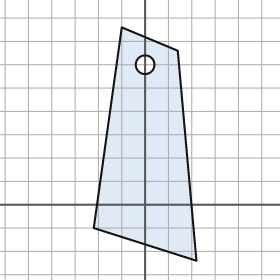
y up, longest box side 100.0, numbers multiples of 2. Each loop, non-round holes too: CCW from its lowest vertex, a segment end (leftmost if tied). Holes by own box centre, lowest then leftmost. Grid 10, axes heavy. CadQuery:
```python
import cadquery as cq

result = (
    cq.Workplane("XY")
    .moveTo(22.0, -24.0)
    .lineTo(14.0, 66.0)
    .lineTo(-10.0, 76.0)
    .lineTo(-22.0, -10.0)
    .close()
    .moveTo(0.0, 60.0)
    .circle(4.0)
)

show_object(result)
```